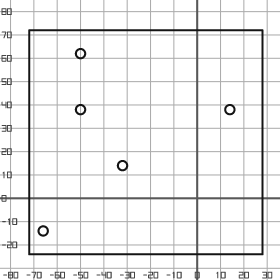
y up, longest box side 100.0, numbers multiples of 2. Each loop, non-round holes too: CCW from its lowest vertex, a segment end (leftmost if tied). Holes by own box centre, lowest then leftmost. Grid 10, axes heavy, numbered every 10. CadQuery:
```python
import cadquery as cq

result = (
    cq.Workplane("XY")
    .moveTo(-72.0, -24.0)
    .lineTo(28.0, -24.0)
    .lineTo(28.0, 72.0)
    .lineTo(-72.0, 72.0)
    .close()
    .moveTo(-66.0, -14.0)
    .circle(2.0)
    .moveTo(-32.0, 14.0)
    .circle(2.0)
    .moveTo(-50.0, 38.0)
    .circle(2.0)
    .moveTo(14.0, 38.0)
    .circle(2.0)
    .moveTo(-50.0, 62.0)
    .circle(2.0)
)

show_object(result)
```